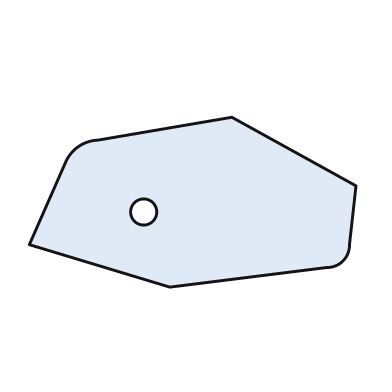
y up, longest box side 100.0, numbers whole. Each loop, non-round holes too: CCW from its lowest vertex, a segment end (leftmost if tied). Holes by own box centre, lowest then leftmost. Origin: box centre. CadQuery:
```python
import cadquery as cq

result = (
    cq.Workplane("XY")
    .moveTo(-7.0, -26.0)
    .lineTo(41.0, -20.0)
    .threePointArc((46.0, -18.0), (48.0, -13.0))
    .lineTo(50.0, 5.0)
    .lineTo(12.0, 26.0)
    .lineTo(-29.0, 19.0)
    .threePointArc((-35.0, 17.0), (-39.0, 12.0))
    .lineTo(-50.0, -13.0)
    .close()
    .moveTo(-15.0, -3.0)
    .circle(4.0)
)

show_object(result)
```